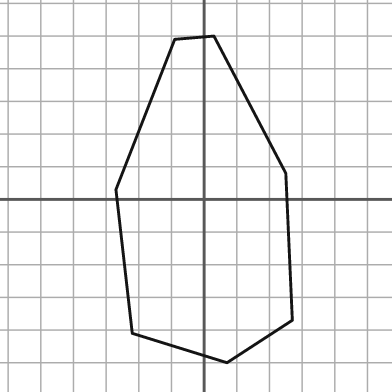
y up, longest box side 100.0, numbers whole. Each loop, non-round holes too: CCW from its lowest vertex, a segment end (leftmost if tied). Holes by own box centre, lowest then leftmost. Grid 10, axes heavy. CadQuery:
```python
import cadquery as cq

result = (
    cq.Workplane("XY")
    .moveTo(7.0, -50.0)
    .lineTo(27.0, -37.0)
    .lineTo(25.0, 8.0)
    .lineTo(3.0, 50.0)
    .lineTo(-9.0, 49.0)
    .lineTo(-27.0, 3.0)
    .lineTo(-22.0, -41.0)
    .close()
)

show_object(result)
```